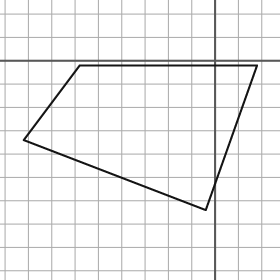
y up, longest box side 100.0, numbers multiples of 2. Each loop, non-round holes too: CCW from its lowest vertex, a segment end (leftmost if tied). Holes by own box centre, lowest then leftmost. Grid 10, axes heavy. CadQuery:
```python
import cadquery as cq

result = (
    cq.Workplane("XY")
    .moveTo(-4.0, -64.0)
    .lineTo(18.0, -2.0)
    .lineTo(-58.0, -2.0)
    .lineTo(-82.0, -34.0)
    .close()
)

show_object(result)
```